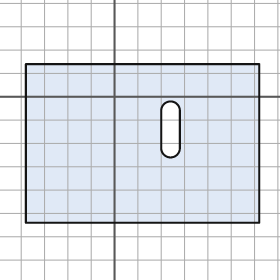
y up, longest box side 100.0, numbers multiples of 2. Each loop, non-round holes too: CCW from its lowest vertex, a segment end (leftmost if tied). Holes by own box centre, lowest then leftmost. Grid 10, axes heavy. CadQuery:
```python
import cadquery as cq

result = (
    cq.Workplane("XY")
    .moveTo(-38.0, -54.0)
    .lineTo(62.0, -54.0)
    .lineTo(62.0, 14.0)
    .lineTo(-38.0, 14.0)
    .close()
    .moveTo(20.0, -22.0)
    .threePointArc((24.0, -26.0), (28.0, -22.0))
    .lineTo(28.0, -6.0)
    .threePointArc((24.0, -2.0), (20.0, -6.0))
    .close()
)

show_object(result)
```